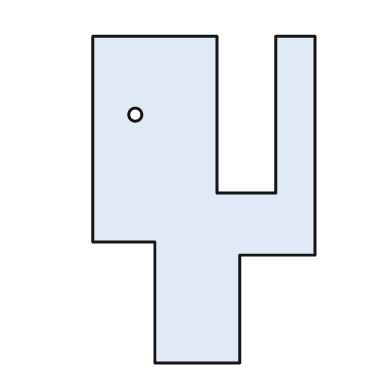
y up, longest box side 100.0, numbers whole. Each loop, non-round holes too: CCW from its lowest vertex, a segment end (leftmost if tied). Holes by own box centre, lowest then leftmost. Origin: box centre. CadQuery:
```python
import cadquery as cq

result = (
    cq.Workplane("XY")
    .moveTo(-15.0, -50.0)
    .lineTo(11.0, -50.0)
    .lineTo(11.0, -17.0)
    .lineTo(34.0, -17.0)
    .lineTo(34.0, 50.0)
    .lineTo(22.0, 50.0)
    .lineTo(22.0, 2.0)
    .lineTo(4.0, 2.0)
    .lineTo(4.0, 50.0)
    .lineTo(-34.0, 50.0)
    .lineTo(-34.0, -13.0)
    .lineTo(-15.0, -13.0)
    .close()
    .moveTo(-21.0, 26.0)
    .circle(2.0)
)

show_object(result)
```